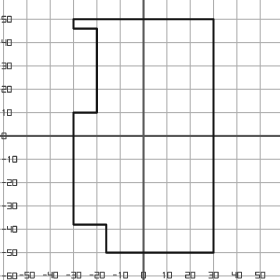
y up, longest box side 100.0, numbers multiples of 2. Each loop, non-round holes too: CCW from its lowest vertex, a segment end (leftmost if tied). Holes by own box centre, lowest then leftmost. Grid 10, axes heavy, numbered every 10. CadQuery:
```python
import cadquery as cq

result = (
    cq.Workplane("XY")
    .moveTo(-16.0, -50.0)
    .lineTo(30.0, -50.0)
    .lineTo(30.0, 50.0)
    .lineTo(-30.0, 50.0)
    .lineTo(-30.0, 46.0)
    .lineTo(-20.0, 46.0)
    .lineTo(-20.0, 10.0)
    .lineTo(-30.0, 10.0)
    .lineTo(-30.0, -38.0)
    .lineTo(-16.0, -38.0)
    .close()
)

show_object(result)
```